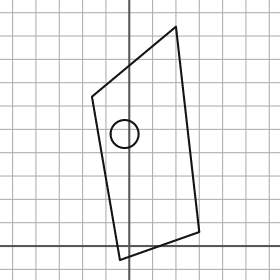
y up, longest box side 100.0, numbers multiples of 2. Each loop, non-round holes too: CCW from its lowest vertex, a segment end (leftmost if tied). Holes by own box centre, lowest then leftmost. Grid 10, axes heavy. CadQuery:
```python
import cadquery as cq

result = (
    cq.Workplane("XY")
    .moveTo(-4.0, -6.0)
    .lineTo(30.0, 6.0)
    .lineTo(20.0, 94.0)
    .lineTo(-16.0, 64.0)
    .close()
    .moveTo(-2.0, 48.0)
    .circle(6.0)
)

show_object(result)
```